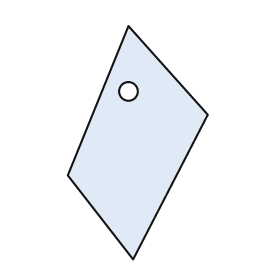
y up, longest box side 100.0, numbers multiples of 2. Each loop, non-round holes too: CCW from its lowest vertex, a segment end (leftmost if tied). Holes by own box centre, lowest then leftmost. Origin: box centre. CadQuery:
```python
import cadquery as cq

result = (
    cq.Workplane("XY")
    .moveTo(-2.0, -50.0)
    .lineTo(30.0, 12.0)
    .lineTo(-4.0, 50.0)
    .lineTo(-30.0, -14.0)
    .close()
    .moveTo(-4.0, 22.0)
    .circle(4.0)
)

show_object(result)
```